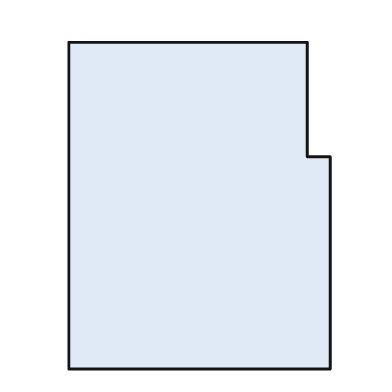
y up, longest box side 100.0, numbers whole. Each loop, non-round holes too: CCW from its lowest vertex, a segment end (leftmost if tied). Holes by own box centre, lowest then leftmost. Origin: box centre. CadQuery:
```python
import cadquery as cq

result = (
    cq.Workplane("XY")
    .moveTo(-40.0, -50.0)
    .lineTo(40.0, -50.0)
    .lineTo(40.0, 15.0)
    .lineTo(33.0, 15.0)
    .lineTo(33.0, 50.0)
    .lineTo(-40.0, 50.0)
    .close()
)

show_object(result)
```